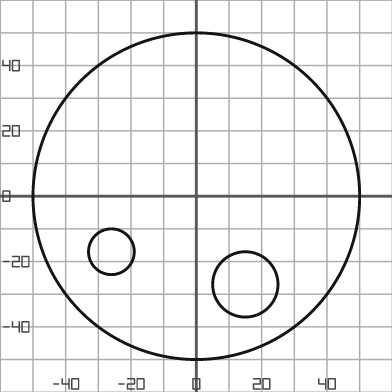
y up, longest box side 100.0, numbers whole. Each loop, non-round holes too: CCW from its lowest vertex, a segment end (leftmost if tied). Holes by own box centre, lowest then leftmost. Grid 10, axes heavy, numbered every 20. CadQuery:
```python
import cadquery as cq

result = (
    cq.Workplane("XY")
    .moveTo(0.0, 0.0)
    .circle(50.0)
    .moveTo(15.0, -27.0)
    .circle(10.0)
    .moveTo(-26.0, -17.0)
    .circle(7.0)
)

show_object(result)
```